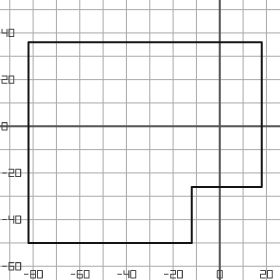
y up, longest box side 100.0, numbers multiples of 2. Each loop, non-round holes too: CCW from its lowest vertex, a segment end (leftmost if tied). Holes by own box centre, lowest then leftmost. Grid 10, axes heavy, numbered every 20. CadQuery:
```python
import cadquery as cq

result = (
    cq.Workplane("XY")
    .moveTo(-82.0, -50.0)
    .lineTo(-12.0, -50.0)
    .lineTo(-12.0, -26.0)
    .lineTo(18.0, -26.0)
    .lineTo(18.0, 36.0)
    .lineTo(-82.0, 36.0)
    .close()
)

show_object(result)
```